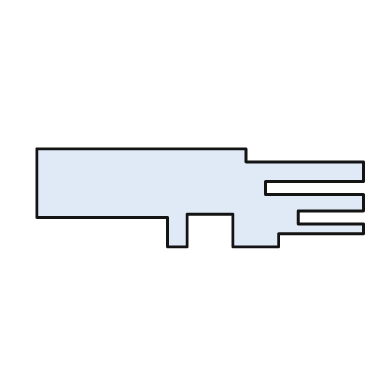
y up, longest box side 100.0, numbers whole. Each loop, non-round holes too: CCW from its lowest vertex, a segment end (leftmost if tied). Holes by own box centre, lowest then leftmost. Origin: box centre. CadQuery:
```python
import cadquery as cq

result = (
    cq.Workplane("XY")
    .moveTo(-10.0, -15.0)
    .lineTo(-4.0, -15.0)
    .lineTo(-4.0, -5.0)
    .lineTo(10.0, -5.0)
    .lineTo(10.0, -15.0)
    .lineTo(24.0, -15.0)
    .lineTo(24.0, -11.0)
    .lineTo(50.0, -11.0)
    .lineTo(50.0, -8.0)
    .lineTo(30.0, -8.0)
    .lineTo(30.0, -4.0)
    .lineTo(50.0, -4.0)
    .lineTo(50.0, 1.0)
    .lineTo(20.0, 1.0)
    .lineTo(20.0, 5.0)
    .lineTo(50.0, 5.0)
    .lineTo(50.0, 11.0)
    .lineTo(14.0, 11.0)
    .lineTo(14.0, 15.0)
    .lineTo(-50.0, 15.0)
    .lineTo(-50.0, -6.0)
    .lineTo(-10.0, -6.0)
    .close()
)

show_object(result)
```